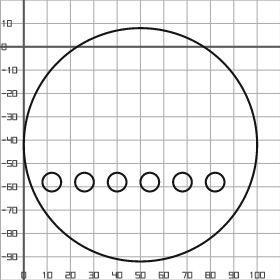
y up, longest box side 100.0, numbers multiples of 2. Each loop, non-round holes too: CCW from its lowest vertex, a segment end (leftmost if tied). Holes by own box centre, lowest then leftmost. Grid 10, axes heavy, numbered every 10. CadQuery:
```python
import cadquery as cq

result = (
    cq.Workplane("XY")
    .moveTo(50.0, -42.0)
    .circle(50.0)
    .moveTo(12.0, -58.0)
    .circle(4.0)
    .moveTo(26.0, -58.0)
    .circle(4.0)
    .moveTo(40.0, -58.0)
    .circle(4.0)
    .moveTo(54.0, -58.0)
    .circle(4.0)
    .moveTo(68.0, -58.0)
    .circle(4.0)
    .moveTo(82.0, -58.0)
    .circle(4.0)
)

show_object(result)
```